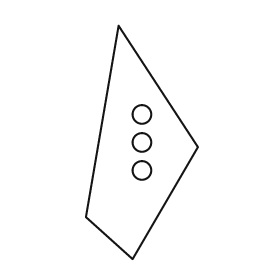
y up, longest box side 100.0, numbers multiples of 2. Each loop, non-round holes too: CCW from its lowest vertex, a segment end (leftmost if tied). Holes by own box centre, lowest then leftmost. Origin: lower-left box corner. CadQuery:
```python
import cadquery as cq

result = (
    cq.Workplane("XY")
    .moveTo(20.0, 0.0)
    .lineTo(48.0, 48.0)
    .lineTo(14.0, 100.0)
    .lineTo(0.0, 18.0)
    .close()
    .moveTo(24.0, 38.0)
    .circle(4.0)
    .moveTo(24.0, 50.0)
    .circle(4.0)
    .moveTo(24.0, 62.0)
    .circle(4.0)
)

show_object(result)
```